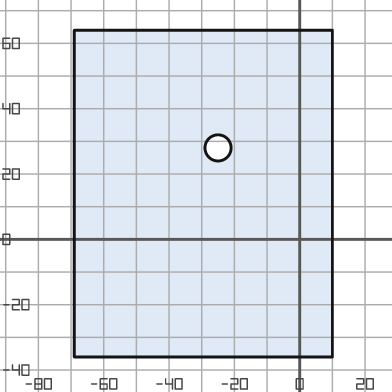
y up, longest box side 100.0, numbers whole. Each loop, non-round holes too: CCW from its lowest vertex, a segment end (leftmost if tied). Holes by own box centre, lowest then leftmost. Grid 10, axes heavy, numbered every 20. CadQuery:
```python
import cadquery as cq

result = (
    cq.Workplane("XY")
    .moveTo(-69.0, -36.0)
    .lineTo(10.0, -36.0)
    .lineTo(10.0, 64.0)
    .lineTo(-69.0, 64.0)
    .close()
    .moveTo(-25.0, 28.0)
    .circle(4.0)
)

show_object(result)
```